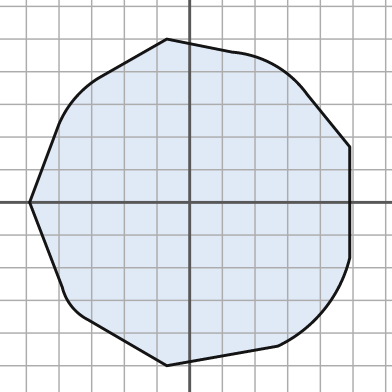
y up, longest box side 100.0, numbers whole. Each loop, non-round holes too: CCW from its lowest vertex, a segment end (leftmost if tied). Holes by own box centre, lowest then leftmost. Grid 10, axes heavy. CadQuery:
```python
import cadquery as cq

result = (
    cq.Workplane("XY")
    .moveTo(-7.0, -50.0)
    .lineTo(27.0, -44.0)
    .threePointArc((41.0, -33.0), (49.0, -17.0))
    .lineTo(49.0, 17.0)
    .lineTo(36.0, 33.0)
    .threePointArc((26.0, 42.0), (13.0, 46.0))
    .lineTo(-7.0, 50.0)
    .lineTo(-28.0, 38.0)
    .threePointArc((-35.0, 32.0), (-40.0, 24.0))
    .lineTo(-49.0, 0.0)
    .lineTo(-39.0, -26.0)
    .threePointArc((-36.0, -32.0), (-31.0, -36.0))
    .close()
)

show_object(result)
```